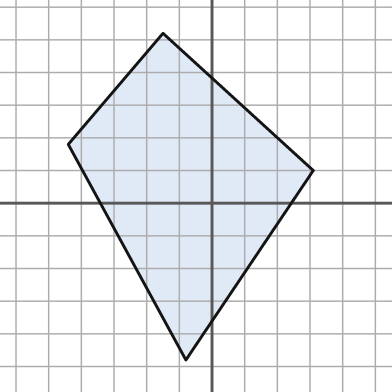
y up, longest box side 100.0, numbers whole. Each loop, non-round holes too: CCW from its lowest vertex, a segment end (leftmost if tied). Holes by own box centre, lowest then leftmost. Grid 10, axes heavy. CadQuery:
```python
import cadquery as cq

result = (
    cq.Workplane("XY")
    .moveTo(-8.0, -48.0)
    .lineTo(31.0, 10.0)
    .lineTo(-15.0, 52.0)
    .lineTo(-44.0, 18.0)
    .close()
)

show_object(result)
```